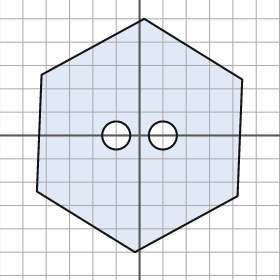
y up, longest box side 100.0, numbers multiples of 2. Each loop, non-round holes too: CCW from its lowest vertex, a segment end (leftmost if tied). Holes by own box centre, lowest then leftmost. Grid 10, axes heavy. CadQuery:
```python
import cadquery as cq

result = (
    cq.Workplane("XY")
    .moveTo(-2.0, -50.0)
    .lineTo(42.0, -26.0)
    .lineTo(44.0, 24.0)
    .lineTo(2.0, 50.0)
    .lineTo(-42.0, 26.0)
    .lineTo(-44.0, -24.0)
    .close()
    .moveTo(-10.0, 0.0)
    .circle(6.0)
    .moveTo(10.0, 0.0)
    .circle(6.0)
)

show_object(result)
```